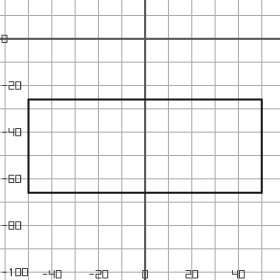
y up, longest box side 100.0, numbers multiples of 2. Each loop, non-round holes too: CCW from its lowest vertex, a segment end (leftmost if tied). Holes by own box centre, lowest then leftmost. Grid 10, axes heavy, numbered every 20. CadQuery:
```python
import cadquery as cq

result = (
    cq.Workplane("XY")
    .moveTo(-50.0, -66.0)
    .lineTo(50.0, -66.0)
    .lineTo(50.0, -26.0)
    .lineTo(-50.0, -26.0)
    .close()
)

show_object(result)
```